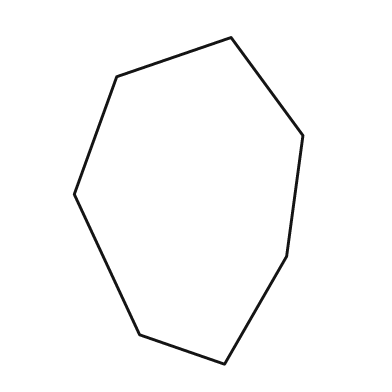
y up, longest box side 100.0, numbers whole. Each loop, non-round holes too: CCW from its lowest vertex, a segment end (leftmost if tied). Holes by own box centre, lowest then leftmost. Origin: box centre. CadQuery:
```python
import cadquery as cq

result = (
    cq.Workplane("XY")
    .moveTo(11.0, -50.0)
    .lineTo(30.0, -17.0)
    .lineTo(35.0, 20.0)
    .lineTo(13.0, 50.0)
    .lineTo(-22.0, 38.0)
    .lineTo(-35.0, 2.0)
    .lineTo(-15.0, -41.0)
    .close()
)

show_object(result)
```